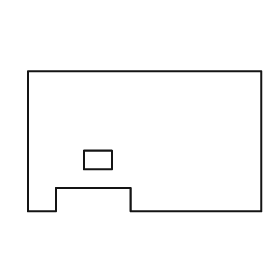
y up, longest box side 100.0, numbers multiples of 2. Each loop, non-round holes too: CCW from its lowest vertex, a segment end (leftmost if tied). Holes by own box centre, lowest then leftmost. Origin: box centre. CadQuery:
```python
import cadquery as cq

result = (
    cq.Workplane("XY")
    .moveTo(-50.0, -30.0)
    .lineTo(-38.0, -30.0)
    .lineTo(-38.0, -20.0)
    .lineTo(-6.0, -20.0)
    .lineTo(-6.0, -30.0)
    .lineTo(50.0, -30.0)
    .lineTo(50.0, 30.0)
    .lineTo(-50.0, 30.0)
    .close()
    .moveTo(-26.0, -12.0)
    .lineTo(-14.0, -12.0)
    .lineTo(-14.0, -4.0)
    .lineTo(-26.0, -4.0)
    .close()
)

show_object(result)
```